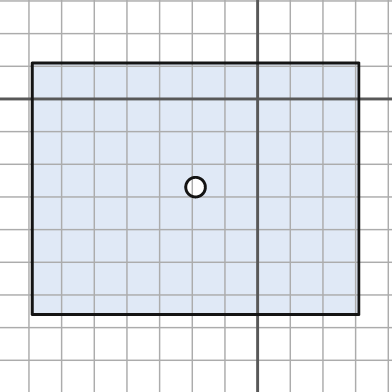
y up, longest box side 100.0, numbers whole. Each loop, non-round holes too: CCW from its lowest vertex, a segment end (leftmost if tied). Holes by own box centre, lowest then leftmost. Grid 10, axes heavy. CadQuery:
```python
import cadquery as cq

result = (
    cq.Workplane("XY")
    .moveTo(-69.0, -66.0)
    .lineTo(31.0, -66.0)
    .lineTo(31.0, 11.0)
    .lineTo(-69.0, 11.0)
    .close()
    .moveTo(-19.0, -27.0)
    .circle(3.0)
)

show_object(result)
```